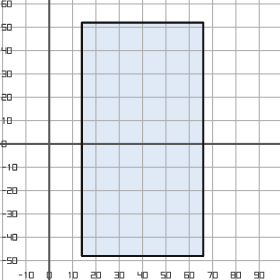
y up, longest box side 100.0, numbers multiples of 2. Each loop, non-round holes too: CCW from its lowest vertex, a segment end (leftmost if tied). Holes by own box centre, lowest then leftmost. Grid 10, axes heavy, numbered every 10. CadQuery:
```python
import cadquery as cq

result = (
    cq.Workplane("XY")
    .moveTo(14.0, -48.0)
    .lineTo(66.0, -48.0)
    .lineTo(66.0, 52.0)
    .lineTo(14.0, 52.0)
    .close()
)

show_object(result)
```